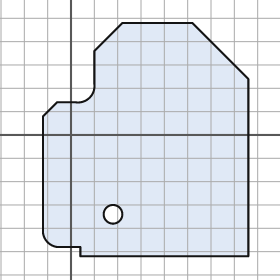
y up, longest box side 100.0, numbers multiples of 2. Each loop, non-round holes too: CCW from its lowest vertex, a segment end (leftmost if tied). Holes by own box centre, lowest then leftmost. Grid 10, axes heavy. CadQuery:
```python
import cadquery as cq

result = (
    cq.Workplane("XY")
    .moveTo(4.0, -52.0)
    .lineTo(76.0, -52.0)
    .lineTo(76.0, 24.0)
    .lineTo(52.0, 48.0)
    .lineTo(22.0, 48.0)
    .lineTo(10.0, 36.0)
    .lineTo(10.0, 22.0)
    .threePointArc((8.0, 16.0), (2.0, 14.0))
    .lineTo(-6.0, 14.0)
    .lineTo(-12.0, 8.0)
    .lineTo(-12.0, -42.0)
    .threePointArc((-10.0, -46.0), (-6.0, -48.0))
    .lineTo(4.0, -48.0)
    .close()
    .moveTo(18.0, -34.0)
    .circle(4.0)
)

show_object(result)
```